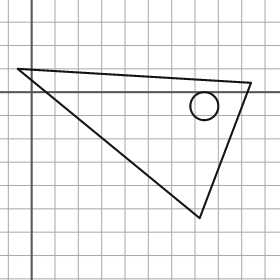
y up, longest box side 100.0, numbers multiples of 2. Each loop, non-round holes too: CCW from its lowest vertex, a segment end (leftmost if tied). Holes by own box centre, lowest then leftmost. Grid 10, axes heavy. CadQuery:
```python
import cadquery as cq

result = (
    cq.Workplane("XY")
    .moveTo(72.0, -54.0)
    .lineTo(94.0, 4.0)
    .lineTo(-6.0, 10.0)
    .close()
    .moveTo(74.0, -6.0)
    .circle(6.0)
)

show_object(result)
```